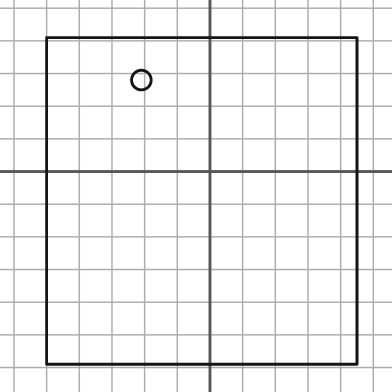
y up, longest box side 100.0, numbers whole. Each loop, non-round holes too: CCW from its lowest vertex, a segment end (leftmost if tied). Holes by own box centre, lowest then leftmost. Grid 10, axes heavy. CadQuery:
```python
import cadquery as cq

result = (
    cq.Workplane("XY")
    .moveTo(-50.0, -59.0)
    .lineTo(45.0, -59.0)
    .lineTo(45.0, 41.0)
    .lineTo(-50.0, 41.0)
    .close()
    .moveTo(-21.0, 28.0)
    .circle(3.0)
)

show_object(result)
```